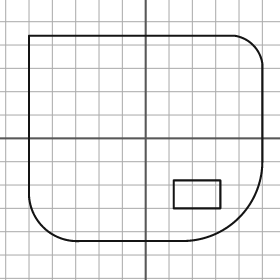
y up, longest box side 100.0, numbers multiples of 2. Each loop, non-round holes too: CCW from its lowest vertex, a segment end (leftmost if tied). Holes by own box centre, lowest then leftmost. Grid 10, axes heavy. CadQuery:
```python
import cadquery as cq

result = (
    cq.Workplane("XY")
    .moveTo(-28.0, -44.0)
    .lineTo(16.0, -44.0)
    .threePointArc((40.0, -34.0), (50.0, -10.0))
    .lineTo(50.0, 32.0)
    .threePointArc((46.0, 40.0), (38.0, 44.0))
    .lineTo(-50.0, 44.0)
    .lineTo(-50.0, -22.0)
    .threePointArc((-44.0, -38.0), (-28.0, -44.0))
    .close()
    .moveTo(12.0, -30.0)
    .lineTo(32.0, -30.0)
    .lineTo(32.0, -18.0)
    .lineTo(12.0, -18.0)
    .close()
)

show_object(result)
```